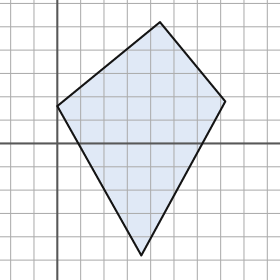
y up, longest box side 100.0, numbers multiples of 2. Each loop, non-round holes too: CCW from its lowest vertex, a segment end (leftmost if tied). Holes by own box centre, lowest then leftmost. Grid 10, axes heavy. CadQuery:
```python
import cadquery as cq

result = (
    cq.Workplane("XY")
    .moveTo(36.0, -48.0)
    .lineTo(72.0, 18.0)
    .lineTo(44.0, 52.0)
    .lineTo(0.0, 16.0)
    .close()
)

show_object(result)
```